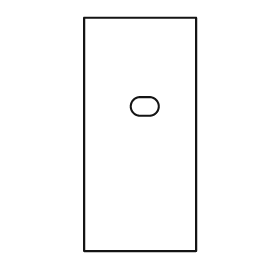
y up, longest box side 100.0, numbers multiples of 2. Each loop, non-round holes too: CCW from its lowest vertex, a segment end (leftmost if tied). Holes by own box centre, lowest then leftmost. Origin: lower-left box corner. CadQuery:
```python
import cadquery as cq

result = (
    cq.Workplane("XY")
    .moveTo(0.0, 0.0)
    .lineTo(48.0, 0.0)
    .lineTo(48.0, 100.0)
    .lineTo(0.0, 100.0)
    .close()
    .moveTo(24.0, 58.0)
    .lineTo(28.0, 58.0)
    .threePointArc((32.0, 62.0), (28.0, 66.0))
    .lineTo(24.0, 66.0)
    .threePointArc((20.0, 62.0), (24.0, 58.0))
    .close()
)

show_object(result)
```